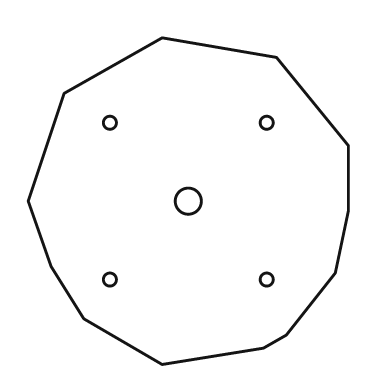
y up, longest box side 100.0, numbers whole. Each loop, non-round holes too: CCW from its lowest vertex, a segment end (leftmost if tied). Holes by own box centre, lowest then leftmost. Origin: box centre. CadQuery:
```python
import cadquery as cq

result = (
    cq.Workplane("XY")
    .moveTo(-8.0, -50.0)
    .lineTo(23.0, -45.0)
    .lineTo(30.0, -41.0)
    .lineTo(45.0, -22.0)
    .lineTo(49.0, -3.0)
    .lineTo(49.0, 17.0)
    .lineTo(27.0, 44.0)
    .lineTo(-8.0, 50.0)
    .lineTo(-38.0, 33.0)
    .lineTo(-49.0, 0.0)
    .lineTo(-42.0, -20.0)
    .lineTo(-32.0, -36.0)
    .close()
    .moveTo(-24.0, -24.0)
    .circle(2.0)
    .moveTo(24.0, -24.0)
    .circle(2.0)
    .moveTo(0.0, 0.0)
    .circle(4.0)
    .moveTo(-24.0, 24.0)
    .circle(2.0)
    .moveTo(24.0, 24.0)
    .circle(2.0)
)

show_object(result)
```